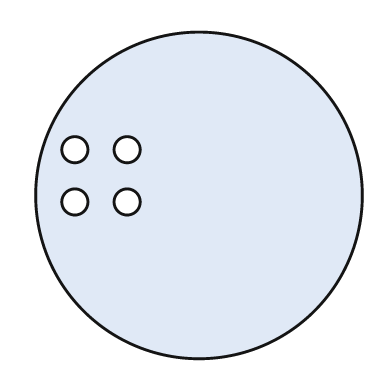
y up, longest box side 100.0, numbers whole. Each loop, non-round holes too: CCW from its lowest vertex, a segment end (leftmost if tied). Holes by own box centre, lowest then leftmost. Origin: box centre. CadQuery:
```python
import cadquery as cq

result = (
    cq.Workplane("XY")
    .moveTo(0.0, 0.0)
    .circle(50.0)
    .moveTo(-38.0, -2.0)
    .circle(4.0)
    .moveTo(-22.0, -2.0)
    .circle(4.0)
    .moveTo(-38.0, 14.0)
    .circle(4.0)
    .moveTo(-22.0, 14.0)
    .circle(4.0)
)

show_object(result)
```